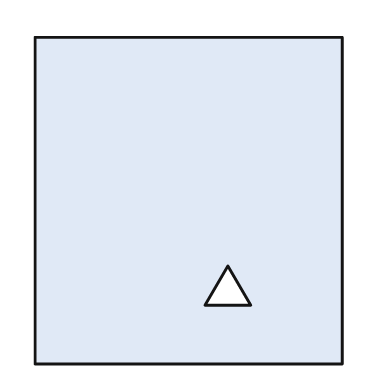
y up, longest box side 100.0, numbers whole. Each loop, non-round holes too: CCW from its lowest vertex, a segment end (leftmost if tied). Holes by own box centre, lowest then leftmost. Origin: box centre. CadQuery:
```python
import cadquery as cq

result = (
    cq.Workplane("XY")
    .moveTo(-47.0, -50.0)
    .lineTo(47.0, -50.0)
    .lineTo(47.0, 50.0)
    .lineTo(-47.0, 50.0)
    .close()
    .moveTo(5.0, -32.0)
    .lineTo(19.0, -32.0)
    .lineTo(12.0, -20.0)
    .close()
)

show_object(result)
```